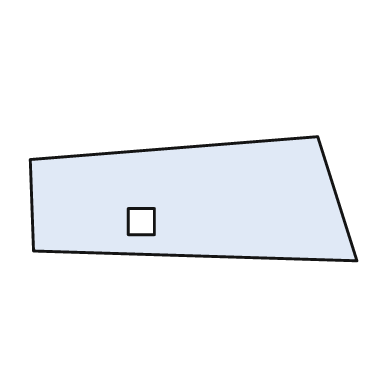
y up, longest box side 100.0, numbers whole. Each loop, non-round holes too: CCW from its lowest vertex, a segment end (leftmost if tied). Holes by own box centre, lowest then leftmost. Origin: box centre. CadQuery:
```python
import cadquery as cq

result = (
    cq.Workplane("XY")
    .moveTo(50.0, -19.0)
    .lineTo(38.0, 19.0)
    .lineTo(-50.0, 12.0)
    .lineTo(-49.0, -16.0)
    .close()
    .moveTo(-20.0, -11.0)
    .lineTo(-12.0, -11.0)
    .lineTo(-12.0, -3.0)
    .lineTo(-20.0, -3.0)
    .close()
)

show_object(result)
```